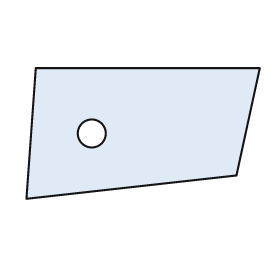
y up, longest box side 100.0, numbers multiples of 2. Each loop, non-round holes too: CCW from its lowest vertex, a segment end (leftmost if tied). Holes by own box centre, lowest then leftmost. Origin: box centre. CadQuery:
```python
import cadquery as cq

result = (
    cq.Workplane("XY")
    .moveTo(-50.0, -28.0)
    .lineTo(40.0, -18.0)
    .lineTo(50.0, 28.0)
    .lineTo(-46.0, 28.0)
    .close()
    .moveTo(-22.0, 0.0)
    .circle(6.0)
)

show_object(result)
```